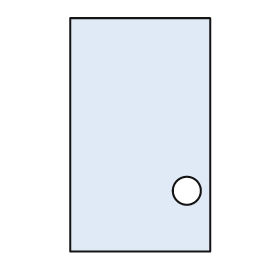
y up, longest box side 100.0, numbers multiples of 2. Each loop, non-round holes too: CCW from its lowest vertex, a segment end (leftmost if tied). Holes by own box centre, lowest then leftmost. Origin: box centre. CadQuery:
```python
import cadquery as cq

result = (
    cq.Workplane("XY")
    .moveTo(-30.0, -50.0)
    .lineTo(30.0, -50.0)
    .lineTo(30.0, 50.0)
    .lineTo(-30.0, 50.0)
    .close()
    .moveTo(20.0, -24.0)
    .circle(6.0)
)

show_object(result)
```